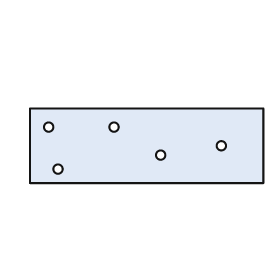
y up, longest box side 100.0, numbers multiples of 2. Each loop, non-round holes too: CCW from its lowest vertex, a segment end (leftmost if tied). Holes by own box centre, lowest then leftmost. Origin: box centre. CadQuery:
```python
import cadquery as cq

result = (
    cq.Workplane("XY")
    .moveTo(-50.0, -16.0)
    .lineTo(50.0, -16.0)
    .lineTo(50.0, 16.0)
    .lineTo(-50.0, 16.0)
    .close()
    .moveTo(-38.0, -10.0)
    .circle(2.0)
    .moveTo(6.0, -4.0)
    .circle(2.0)
    .moveTo(32.0, 0.0)
    .circle(2.0)
    .moveTo(-42.0, 8.0)
    .circle(2.0)
    .moveTo(-14.0, 8.0)
    .circle(2.0)
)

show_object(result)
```